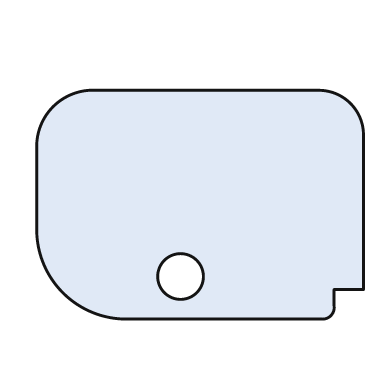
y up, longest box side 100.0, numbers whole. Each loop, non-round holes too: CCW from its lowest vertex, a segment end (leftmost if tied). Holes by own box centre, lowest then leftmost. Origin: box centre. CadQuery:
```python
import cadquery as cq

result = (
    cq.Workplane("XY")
    .moveTo(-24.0, -35.0)
    .lineTo(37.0, -35.0)
    .threePointArc((40.0, -34.0), (41.0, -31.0))
    .lineTo(41.0, -26.0)
    .lineTo(50.0, -26.0)
    .lineTo(50.0, 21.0)
    .threePointArc((46.0, 31.0), (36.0, 35.0))
    .lineTo(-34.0, 35.0)
    .threePointArc((-45.0, 30.0), (-50.0, 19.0))
    .lineTo(-50.0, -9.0)
    .threePointArc((-42.0, -27.0), (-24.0, -35.0))
    .close()
    .moveTo(-6.0, -22.0)
    .circle(7.0)
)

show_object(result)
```